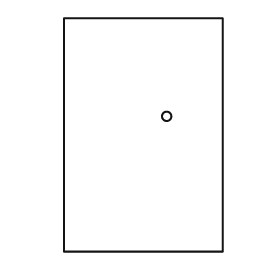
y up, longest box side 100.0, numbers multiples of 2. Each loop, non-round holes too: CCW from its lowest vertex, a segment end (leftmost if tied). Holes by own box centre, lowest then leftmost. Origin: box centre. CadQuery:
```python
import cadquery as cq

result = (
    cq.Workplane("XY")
    .moveTo(-34.0, -50.0)
    .lineTo(34.0, -50.0)
    .lineTo(34.0, 50.0)
    .lineTo(-34.0, 50.0)
    .close()
    .moveTo(10.0, 8.0)
    .circle(2.0)
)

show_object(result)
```